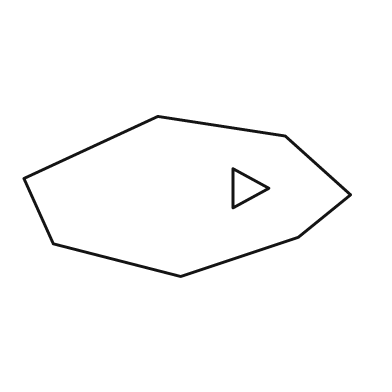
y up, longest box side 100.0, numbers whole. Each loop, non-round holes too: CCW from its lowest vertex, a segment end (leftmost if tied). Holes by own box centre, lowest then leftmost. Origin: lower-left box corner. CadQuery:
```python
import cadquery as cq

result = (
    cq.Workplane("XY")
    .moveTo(48.0, 0.0)
    .lineTo(84.0, 12.0)
    .lineTo(100.0, 25.0)
    .lineTo(80.0, 43.0)
    .lineTo(41.0, 49.0)
    .lineTo(0.0, 30.0)
    .lineTo(9.0, 10.0)
    .close()
    .moveTo(64.0, 21.0)
    .lineTo(75.0, 27.0)
    .lineTo(64.0, 33.0)
    .close()
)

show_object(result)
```